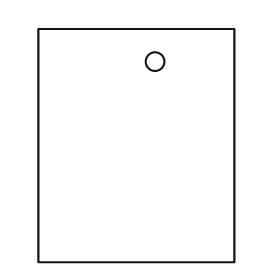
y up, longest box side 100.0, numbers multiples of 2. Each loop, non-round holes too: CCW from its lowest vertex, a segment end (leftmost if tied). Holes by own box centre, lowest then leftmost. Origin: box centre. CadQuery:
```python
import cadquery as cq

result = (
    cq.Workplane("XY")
    .moveTo(-42.0, -50.0)
    .lineTo(42.0, -50.0)
    .lineTo(42.0, 50.0)
    .lineTo(-42.0, 50.0)
    .close()
    .moveTo(8.0, 36.0)
    .circle(4.0)
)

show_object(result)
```